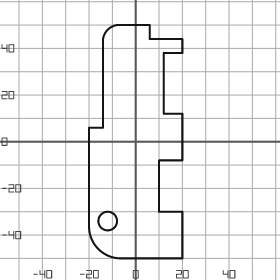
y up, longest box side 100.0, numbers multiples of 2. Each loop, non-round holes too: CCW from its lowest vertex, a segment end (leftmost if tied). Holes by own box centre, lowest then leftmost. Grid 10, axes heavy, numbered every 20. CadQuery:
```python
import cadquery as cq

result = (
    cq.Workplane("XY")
    .moveTo(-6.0, -50.0)
    .lineTo(20.0, -50.0)
    .lineTo(20.0, -30.0)
    .lineTo(10.0, -30.0)
    .lineTo(10.0, -8.0)
    .lineTo(20.0, -8.0)
    .lineTo(20.0, 12.0)
    .lineTo(12.0, 12.0)
    .lineTo(12.0, 38.0)
    .lineTo(20.0, 38.0)
    .lineTo(20.0, 44.0)
    .lineTo(6.0, 44.0)
    .lineTo(6.0, 50.0)
    .lineTo(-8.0, 50.0)
    .threePointArc((-12.0, 48.0), (-14.0, 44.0))
    .lineTo(-14.0, 6.0)
    .lineTo(-20.0, 6.0)
    .lineTo(-20.0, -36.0)
    .threePointArc((-16.0, -46.0), (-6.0, -50.0))
    .close()
    .moveTo(-12.0, -34.0)
    .circle(4.0)
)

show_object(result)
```